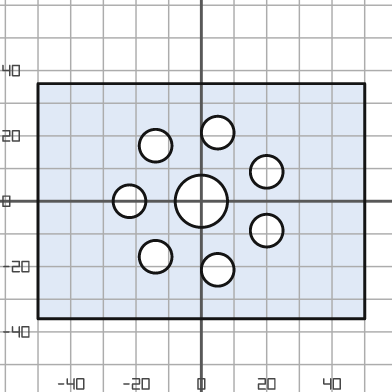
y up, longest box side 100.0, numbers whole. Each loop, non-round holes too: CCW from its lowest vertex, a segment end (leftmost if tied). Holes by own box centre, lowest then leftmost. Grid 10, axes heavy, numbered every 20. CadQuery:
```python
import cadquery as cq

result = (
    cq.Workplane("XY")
    .moveTo(-50.0, -36.0)
    .lineTo(50.0, -36.0)
    .lineTo(50.0, 36.0)
    .lineTo(-50.0, 36.0)
    .close()
    .moveTo(5.0, -21.0)
    .circle(5.0)
    .moveTo(-14.0, -17.0)
    .circle(5.0)
    .moveTo(20.0, -9.0)
    .circle(5.0)
    .moveTo(-22.0, 0.0)
    .circle(5.0)
    .moveTo(0.0, 0.0)
    .circle(8.0)
    .moveTo(20.0, 9.0)
    .circle(5.0)
    .moveTo(-14.0, 17.0)
    .circle(5.0)
    .moveTo(5.0, 21.0)
    .circle(5.0)
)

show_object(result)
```